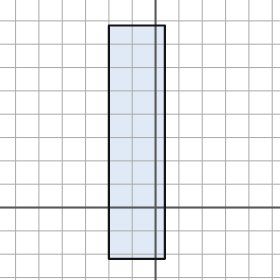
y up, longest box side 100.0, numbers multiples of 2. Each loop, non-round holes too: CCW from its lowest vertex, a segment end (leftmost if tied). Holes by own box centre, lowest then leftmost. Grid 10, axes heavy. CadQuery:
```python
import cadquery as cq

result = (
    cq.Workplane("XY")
    .moveTo(-20.0, -22.0)
    .lineTo(4.0, -22.0)
    .lineTo(4.0, 78.0)
    .lineTo(-20.0, 78.0)
    .close()
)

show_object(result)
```